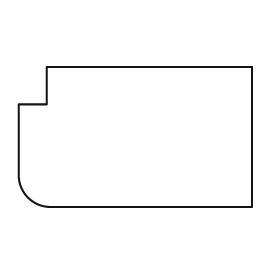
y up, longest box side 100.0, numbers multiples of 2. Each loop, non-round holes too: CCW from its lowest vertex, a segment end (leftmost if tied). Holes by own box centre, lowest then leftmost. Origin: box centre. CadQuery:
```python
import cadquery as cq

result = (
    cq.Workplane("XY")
    .moveTo(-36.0, -30.0)
    .lineTo(50.0, -30.0)
    .lineTo(50.0, 30.0)
    .lineTo(-38.0, 30.0)
    .lineTo(-38.0, 14.0)
    .lineTo(-50.0, 14.0)
    .lineTo(-50.0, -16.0)
    .threePointArc((-46.0, -26.0), (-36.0, -30.0))
    .close()
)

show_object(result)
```